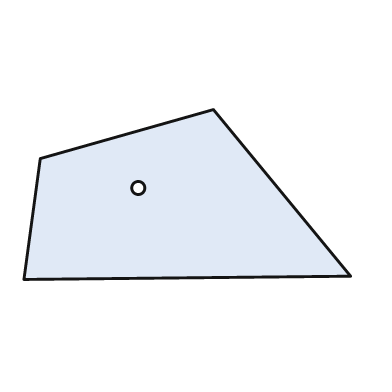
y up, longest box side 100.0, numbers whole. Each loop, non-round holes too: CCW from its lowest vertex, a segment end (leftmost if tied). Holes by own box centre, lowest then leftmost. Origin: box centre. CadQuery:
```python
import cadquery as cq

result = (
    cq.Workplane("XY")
    .moveTo(-50.0, -26.0)
    .lineTo(50.0, -25.0)
    .lineTo(8.0, 26.0)
    .lineTo(-45.0, 11.0)
    .close()
    .moveTo(-15.0, 2.0)
    .circle(2.0)
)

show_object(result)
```